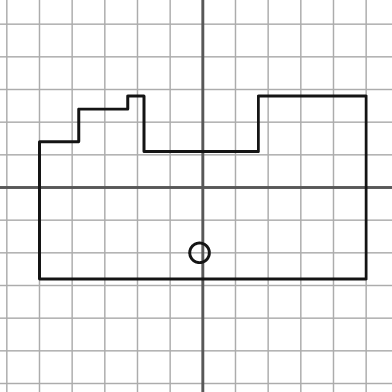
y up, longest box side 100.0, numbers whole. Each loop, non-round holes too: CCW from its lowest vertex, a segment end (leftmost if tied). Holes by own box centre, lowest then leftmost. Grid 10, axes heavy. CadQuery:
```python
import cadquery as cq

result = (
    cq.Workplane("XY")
    .moveTo(-50.0, -28.0)
    .lineTo(50.0, -28.0)
    .lineTo(50.0, 28.0)
    .lineTo(17.0, 28.0)
    .lineTo(17.0, 11.0)
    .lineTo(-18.0, 11.0)
    .lineTo(-18.0, 28.0)
    .lineTo(-23.0, 28.0)
    .lineTo(-23.0, 24.0)
    .lineTo(-38.0, 24.0)
    .lineTo(-38.0, 14.0)
    .lineTo(-50.0, 14.0)
    .close()
    .moveTo(-1.0, -20.0)
    .circle(3.0)
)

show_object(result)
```